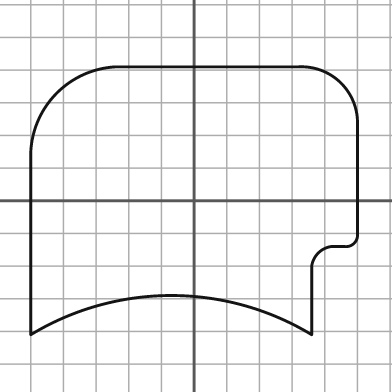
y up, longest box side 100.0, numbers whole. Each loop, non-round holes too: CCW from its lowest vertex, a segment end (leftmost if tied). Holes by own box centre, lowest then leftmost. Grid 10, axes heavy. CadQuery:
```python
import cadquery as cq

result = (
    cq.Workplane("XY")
    .moveTo(-50.0, -41.0)
    .threePointArc((-7.0, -29.0), (36.0, -41.0))
    .lineTo(36.0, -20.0)
    .threePointArc((38.0, -16.0), (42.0, -14.0))
    .lineTo(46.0, -14.0)
    .threePointArc((49.0, -13.0), (50.0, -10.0))
    .lineTo(50.0, 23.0)
    .threePointArc((45.0, 36.0), (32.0, 41.0))
    .lineTo(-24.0, 41.0)
    .threePointArc((-42.0, 33.0), (-50.0, 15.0))
    .close()
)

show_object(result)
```